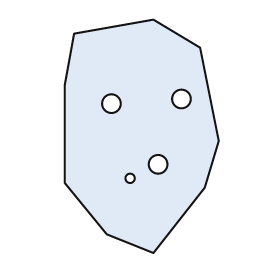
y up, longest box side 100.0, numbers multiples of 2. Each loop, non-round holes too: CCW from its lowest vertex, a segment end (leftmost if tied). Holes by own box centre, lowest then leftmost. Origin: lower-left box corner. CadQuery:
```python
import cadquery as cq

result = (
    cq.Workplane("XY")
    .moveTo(38.0, 0.0)
    .lineTo(60.0, 28.0)
    .lineTo(66.0, 48.0)
    .lineTo(58.0, 88.0)
    .lineTo(38.0, 100.0)
    .lineTo(4.0, 94.0)
    .lineTo(0.0, 72.0)
    .lineTo(0.0, 30.0)
    .lineTo(18.0, 8.0)
    .close()
    .moveTo(28.0, 32.0)
    .circle(2.0)
    .moveTo(40.0, 38.0)
    .circle(4.0)
    .moveTo(20.0, 64.0)
    .circle(4.0)
    .moveTo(50.0, 66.0)
    .circle(4.0)
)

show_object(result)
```